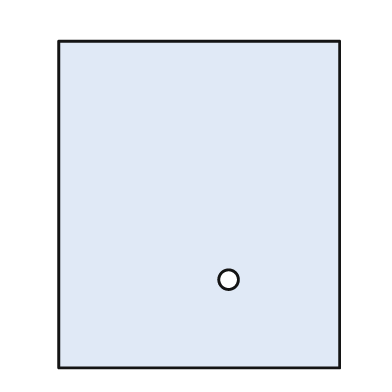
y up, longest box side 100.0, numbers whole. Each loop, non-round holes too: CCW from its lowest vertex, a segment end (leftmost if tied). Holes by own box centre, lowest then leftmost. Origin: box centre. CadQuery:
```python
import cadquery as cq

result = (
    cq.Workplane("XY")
    .moveTo(-43.0, -50.0)
    .lineTo(43.0, -50.0)
    .lineTo(43.0, 50.0)
    .lineTo(-43.0, 50.0)
    .close()
    .moveTo(9.0, -23.0)
    .circle(3.0)
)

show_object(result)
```